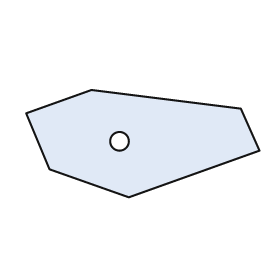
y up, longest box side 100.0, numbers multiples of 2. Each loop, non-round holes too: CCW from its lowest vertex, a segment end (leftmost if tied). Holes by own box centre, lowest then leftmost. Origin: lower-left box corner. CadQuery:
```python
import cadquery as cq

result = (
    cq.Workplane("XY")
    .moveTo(44.0, 0.0)
    .lineTo(100.0, 20.0)
    .lineTo(92.0, 38.0)
    .lineTo(28.0, 46.0)
    .lineTo(0.0, 36.0)
    .lineTo(10.0, 12.0)
    .close()
    .moveTo(40.0, 24.0)
    .circle(4.0)
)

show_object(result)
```